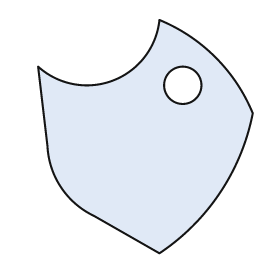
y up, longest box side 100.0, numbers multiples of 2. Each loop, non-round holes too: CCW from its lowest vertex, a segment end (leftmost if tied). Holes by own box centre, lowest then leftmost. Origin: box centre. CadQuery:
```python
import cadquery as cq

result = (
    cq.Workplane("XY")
    .moveTo(6.0, -50.0)
    .threePointArc((32.0, -24.0), (46.0, 10.0))
    .threePointArc((30.0, 34.0), (6.0, 50.0))
    .threePointArc((-14.0, 24.0), (-46.0, 30.0))
    .lineTo(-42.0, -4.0)
    .threePointArc((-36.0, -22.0), (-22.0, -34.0))
    .close()
    .moveTo(16.0, 22.0)
    .circle(8.0)
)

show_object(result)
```